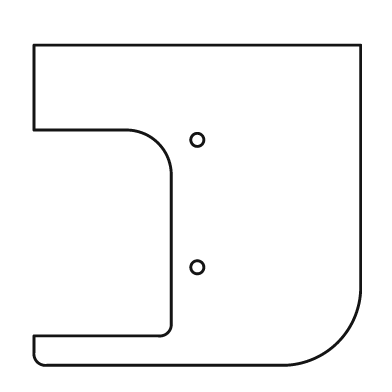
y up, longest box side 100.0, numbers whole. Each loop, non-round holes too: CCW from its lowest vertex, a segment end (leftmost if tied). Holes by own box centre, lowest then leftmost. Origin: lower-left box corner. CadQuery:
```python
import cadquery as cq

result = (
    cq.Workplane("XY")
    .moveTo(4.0, 0.0)
    .lineTo(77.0, 0.0)
    .threePointArc((93.0, 7.0), (100.0, 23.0))
    .lineTo(100.0, 98.0)
    .lineTo(0.0, 98.0)
    .lineTo(0.0, 72.0)
    .lineTo(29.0, 72.0)
    .threePointArc((38.0, 68.0), (42.0, 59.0))
    .lineTo(42.0, 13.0)
    .threePointArc((41.0, 10.0), (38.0, 9.0))
    .lineTo(0.0, 9.0)
    .lineTo(0.0, 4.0)
    .threePointArc((1.0, 1.0), (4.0, 0.0))
    .close()
    .moveTo(50.0, 30.0)
    .circle(2.0)
    .moveTo(50.0, 69.0)
    .circle(2.0)
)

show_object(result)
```